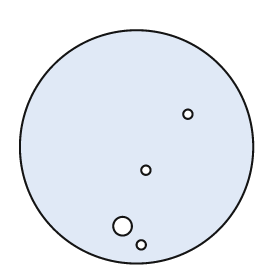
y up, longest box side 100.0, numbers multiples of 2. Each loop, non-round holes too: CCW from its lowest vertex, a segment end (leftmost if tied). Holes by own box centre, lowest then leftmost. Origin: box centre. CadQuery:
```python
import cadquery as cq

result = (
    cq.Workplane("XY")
    .moveTo(0.0, 0.0)
    .circle(50.0)
    .moveTo(2.0, -42.0)
    .circle(2.0)
    .moveTo(-6.0, -34.0)
    .circle(4.0)
    .moveTo(4.0, -10.0)
    .circle(2.0)
    .moveTo(22.0, 14.0)
    .circle(2.0)
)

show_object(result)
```